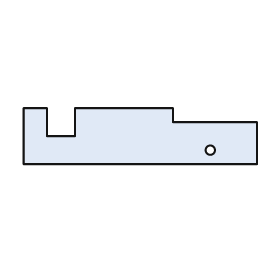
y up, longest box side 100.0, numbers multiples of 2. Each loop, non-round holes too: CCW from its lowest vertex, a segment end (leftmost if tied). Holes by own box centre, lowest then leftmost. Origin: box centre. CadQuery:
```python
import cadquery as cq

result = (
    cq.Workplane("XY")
    .moveTo(-50.0, -12.0)
    .lineTo(50.0, -12.0)
    .lineTo(50.0, 6.0)
    .lineTo(14.0, 6.0)
    .lineTo(14.0, 12.0)
    .lineTo(-28.0, 12.0)
    .lineTo(-28.0, 0.0)
    .lineTo(-40.0, 0.0)
    .lineTo(-40.0, 12.0)
    .lineTo(-50.0, 12.0)
    .close()
    .moveTo(30.0, -6.0)
    .circle(2.0)
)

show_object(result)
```